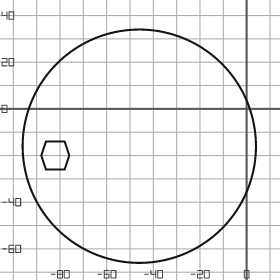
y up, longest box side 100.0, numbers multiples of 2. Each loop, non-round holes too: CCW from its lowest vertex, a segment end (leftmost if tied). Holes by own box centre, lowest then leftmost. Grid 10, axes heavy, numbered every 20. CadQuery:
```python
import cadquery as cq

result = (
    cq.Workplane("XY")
    .moveTo(-46.0, -16.0)
    .circle(50.0)
    .moveTo(-86.0, -26.0)
    .lineTo(-78.0, -26.0)
    .lineTo(-76.0, -20.0)
    .lineTo(-78.0, -14.0)
    .lineTo(-86.0, -14.0)
    .lineTo(-88.0, -20.0)
    .close()
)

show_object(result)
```